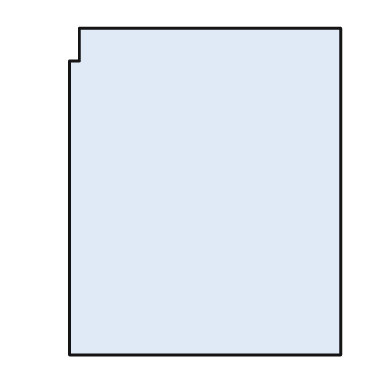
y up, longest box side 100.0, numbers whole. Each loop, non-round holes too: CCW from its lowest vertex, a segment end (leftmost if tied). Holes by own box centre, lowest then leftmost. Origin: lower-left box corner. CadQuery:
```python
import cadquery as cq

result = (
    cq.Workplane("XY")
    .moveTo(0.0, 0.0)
    .lineTo(83.0, 0.0)
    .lineTo(83.0, 100.0)
    .lineTo(3.0, 100.0)
    .lineTo(3.0, 90.0)
    .lineTo(0.0, 90.0)
    .close()
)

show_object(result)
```